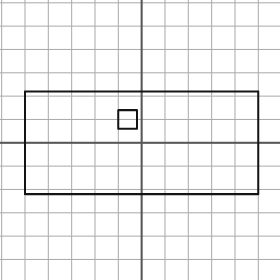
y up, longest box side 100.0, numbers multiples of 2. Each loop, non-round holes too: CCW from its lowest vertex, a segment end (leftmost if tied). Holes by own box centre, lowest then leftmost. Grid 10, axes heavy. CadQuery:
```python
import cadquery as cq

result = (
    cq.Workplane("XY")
    .moveTo(-50.0, -22.0)
    .lineTo(50.0, -22.0)
    .lineTo(50.0, 22.0)
    .lineTo(-50.0, 22.0)
    .close()
    .moveTo(-10.0, 6.0)
    .lineTo(-2.0, 6.0)
    .lineTo(-2.0, 14.0)
    .lineTo(-10.0, 14.0)
    .close()
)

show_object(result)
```